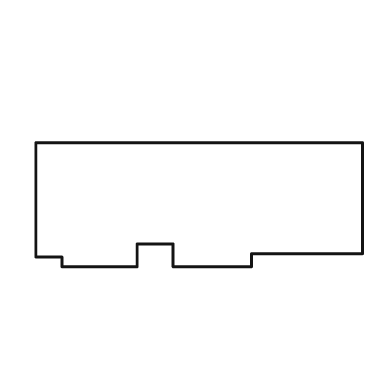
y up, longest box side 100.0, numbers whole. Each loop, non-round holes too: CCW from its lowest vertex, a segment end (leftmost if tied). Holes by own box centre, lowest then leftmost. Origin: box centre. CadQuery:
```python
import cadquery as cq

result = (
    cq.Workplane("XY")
    .moveTo(-42.0, -19.0)
    .lineTo(-19.0, -19.0)
    .lineTo(-19.0, -12.0)
    .lineTo(-8.0, -12.0)
    .lineTo(-8.0, -19.0)
    .lineTo(16.0, -19.0)
    .lineTo(16.0, -15.0)
    .lineTo(50.0, -15.0)
    .lineTo(50.0, 19.0)
    .lineTo(-50.0, 19.0)
    .lineTo(-50.0, -16.0)
    .lineTo(-42.0, -16.0)
    .close()
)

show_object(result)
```